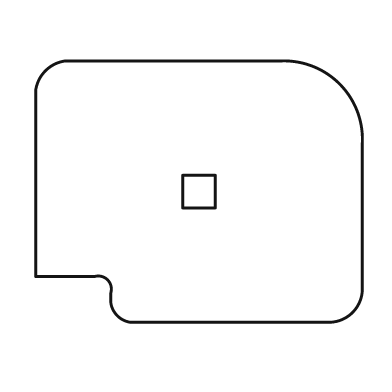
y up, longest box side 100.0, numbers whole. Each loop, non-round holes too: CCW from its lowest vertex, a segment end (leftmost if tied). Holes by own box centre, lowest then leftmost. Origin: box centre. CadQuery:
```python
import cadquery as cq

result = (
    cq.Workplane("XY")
    .moveTo(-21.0, -40.0)
    .lineTo(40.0, -40.0)
    .threePointArc((47.0, -37.0), (50.0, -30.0))
    .lineTo(50.0, 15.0)
    .threePointArc((43.0, 33.0), (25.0, 40.0))
    .lineTo(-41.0, 40.0)
    .threePointArc((-47.0, 37.0), (-50.0, 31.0))
    .lineTo(-50.0, -26.0)
    .lineTo(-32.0, -26.0)
    .threePointArc((-28.0, -27.0), (-27.0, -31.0))
    .lineTo(-27.0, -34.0)
    .threePointArc((-25.0, -38.0), (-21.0, -40.0))
    .close()
    .moveTo(-5.0, -5.0)
    .lineTo(5.0, -5.0)
    .lineTo(5.0, 5.0)
    .lineTo(-5.0, 5.0)
    .close()
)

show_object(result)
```